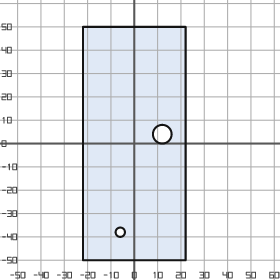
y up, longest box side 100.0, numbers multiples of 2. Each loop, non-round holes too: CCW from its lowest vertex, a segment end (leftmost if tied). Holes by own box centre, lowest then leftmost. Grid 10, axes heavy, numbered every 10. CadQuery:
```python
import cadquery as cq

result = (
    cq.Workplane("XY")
    .moveTo(-22.0, -50.0)
    .lineTo(22.0, -50.0)
    .lineTo(22.0, 50.0)
    .lineTo(-22.0, 50.0)
    .close()
    .moveTo(-6.0, -38.0)
    .circle(2.0)
    .moveTo(12.0, 4.0)
    .circle(4.0)
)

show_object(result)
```